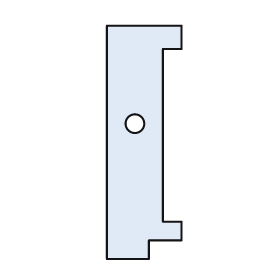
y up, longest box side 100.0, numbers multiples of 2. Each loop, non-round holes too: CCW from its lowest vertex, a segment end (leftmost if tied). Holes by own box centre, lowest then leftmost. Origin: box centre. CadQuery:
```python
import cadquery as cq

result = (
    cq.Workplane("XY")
    .moveTo(-16.0, -50.0)
    .lineTo(2.0, -50.0)
    .lineTo(2.0, -42.0)
    .lineTo(16.0, -42.0)
    .lineTo(16.0, -34.0)
    .lineTo(8.0, -34.0)
    .lineTo(8.0, 40.0)
    .lineTo(16.0, 40.0)
    .lineTo(16.0, 50.0)
    .lineTo(-16.0, 50.0)
    .close()
    .moveTo(-4.0, 8.0)
    .circle(4.0)
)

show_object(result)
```